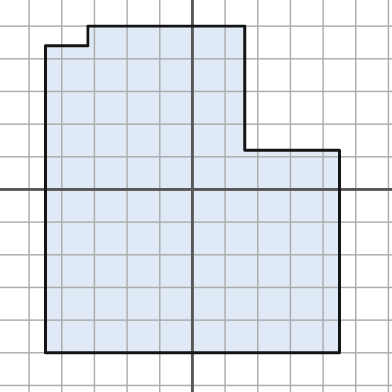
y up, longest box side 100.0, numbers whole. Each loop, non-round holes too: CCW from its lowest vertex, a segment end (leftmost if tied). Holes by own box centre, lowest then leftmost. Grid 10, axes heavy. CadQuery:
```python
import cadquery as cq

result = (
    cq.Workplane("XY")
    .moveTo(-45.0, -50.0)
    .lineTo(45.0, -50.0)
    .lineTo(45.0, 12.0)
    .lineTo(16.0, 12.0)
    .lineTo(16.0, 50.0)
    .lineTo(-32.0, 50.0)
    .lineTo(-32.0, 44.0)
    .lineTo(-45.0, 44.0)
    .close()
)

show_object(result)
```